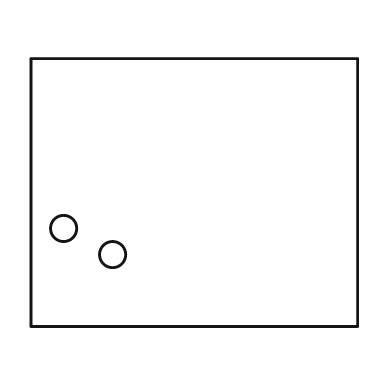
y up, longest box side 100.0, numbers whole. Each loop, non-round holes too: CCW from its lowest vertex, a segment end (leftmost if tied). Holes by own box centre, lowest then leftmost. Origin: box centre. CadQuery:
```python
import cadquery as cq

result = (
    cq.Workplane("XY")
    .moveTo(-50.0, -41.0)
    .lineTo(50.0, -41.0)
    .lineTo(50.0, 41.0)
    .lineTo(-50.0, 41.0)
    .close()
    .moveTo(-25.0, -19.0)
    .circle(4.0)
    .moveTo(-40.0, -11.0)
    .circle(4.0)
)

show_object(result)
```